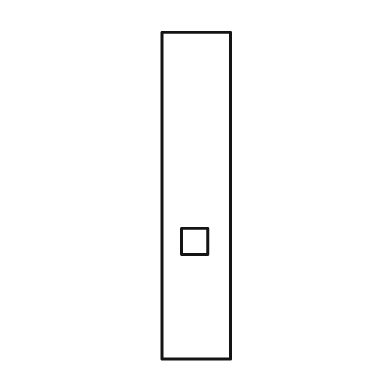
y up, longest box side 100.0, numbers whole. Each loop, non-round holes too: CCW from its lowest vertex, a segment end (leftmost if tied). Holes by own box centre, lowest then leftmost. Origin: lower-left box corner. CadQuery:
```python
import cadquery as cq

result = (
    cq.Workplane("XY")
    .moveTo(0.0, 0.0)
    .lineTo(21.0, 0.0)
    .lineTo(21.0, 100.0)
    .lineTo(0.0, 100.0)
    .close()
    .moveTo(6.0, 32.0)
    .lineTo(14.0, 32.0)
    .lineTo(14.0, 40.0)
    .lineTo(6.0, 40.0)
    .close()
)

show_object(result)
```